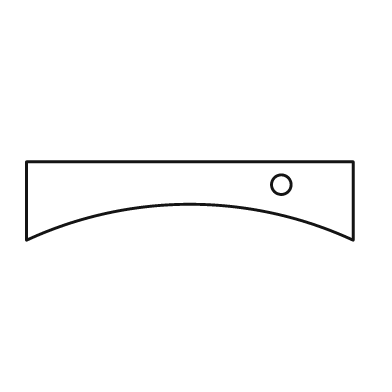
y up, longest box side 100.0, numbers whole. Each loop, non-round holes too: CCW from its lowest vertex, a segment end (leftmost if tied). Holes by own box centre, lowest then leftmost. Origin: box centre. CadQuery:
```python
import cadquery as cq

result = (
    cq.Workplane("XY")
    .moveTo(-50.0, -12.0)
    .threePointArc((0.0, -1.0), (50.0, -12.0))
    .lineTo(50.0, 12.0)
    .lineTo(-50.0, 12.0)
    .close()
    .moveTo(28.0, 5.0)
    .circle(3.0)
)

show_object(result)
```